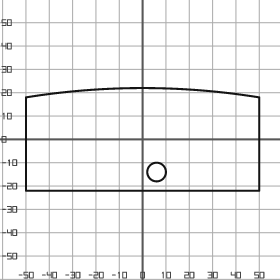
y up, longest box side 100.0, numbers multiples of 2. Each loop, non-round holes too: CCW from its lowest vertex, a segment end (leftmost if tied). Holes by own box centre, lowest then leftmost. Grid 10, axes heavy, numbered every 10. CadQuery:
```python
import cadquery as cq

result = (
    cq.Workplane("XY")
    .moveTo(-50.0, -22.0)
    .lineTo(50.0, -22.0)
    .lineTo(50.0, 18.0)
    .threePointArc((0.0, 22.0), (-50.0, 18.0))
    .close()
    .moveTo(6.0, -14.0)
    .circle(4.0)
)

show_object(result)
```